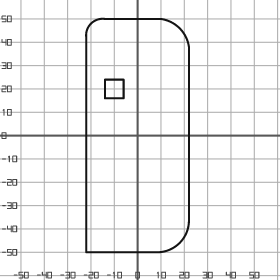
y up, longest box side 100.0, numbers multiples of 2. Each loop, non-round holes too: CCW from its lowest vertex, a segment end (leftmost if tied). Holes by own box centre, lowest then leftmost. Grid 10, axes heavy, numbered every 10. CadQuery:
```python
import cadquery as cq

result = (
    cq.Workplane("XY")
    .moveTo(-22.0, -50.0)
    .lineTo(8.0, -50.0)
    .threePointArc((18.0, -46.0), (22.0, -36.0))
    .lineTo(22.0, 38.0)
    .threePointArc((18.0, 46.0), (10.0, 50.0))
    .lineTo(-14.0, 50.0)
    .threePointArc((-20.0, 48.0), (-22.0, 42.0))
    .close()
    .moveTo(-14.0, 16.0)
    .lineTo(-6.0, 16.0)
    .lineTo(-6.0, 24.0)
    .lineTo(-14.0, 24.0)
    .close()
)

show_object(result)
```